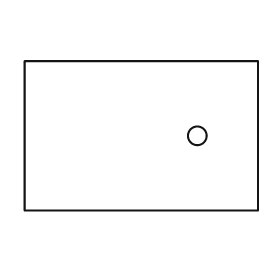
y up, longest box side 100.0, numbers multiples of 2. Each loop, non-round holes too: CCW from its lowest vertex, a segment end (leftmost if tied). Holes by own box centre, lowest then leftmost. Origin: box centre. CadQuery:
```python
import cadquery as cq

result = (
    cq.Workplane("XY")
    .moveTo(-50.0, -32.0)
    .lineTo(50.0, -32.0)
    .lineTo(50.0, 32.0)
    .lineTo(-50.0, 32.0)
    .close()
    .moveTo(24.0, 0.0)
    .circle(4.0)
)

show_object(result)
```